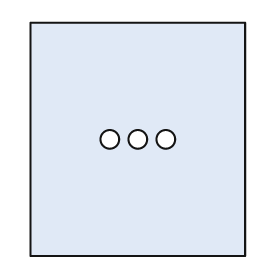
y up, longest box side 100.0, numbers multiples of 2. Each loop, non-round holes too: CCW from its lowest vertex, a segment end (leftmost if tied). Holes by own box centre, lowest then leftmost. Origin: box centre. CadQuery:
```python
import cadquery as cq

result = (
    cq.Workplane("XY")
    .moveTo(-46.0, -50.0)
    .lineTo(46.0, -50.0)
    .lineTo(46.0, 50.0)
    .lineTo(-46.0, 50.0)
    .close()
    .moveTo(-12.0, 0.0)
    .circle(4.0)
    .moveTo(0.0, 0.0)
    .circle(4.0)
    .moveTo(12.0, 0.0)
    .circle(4.0)
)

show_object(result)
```